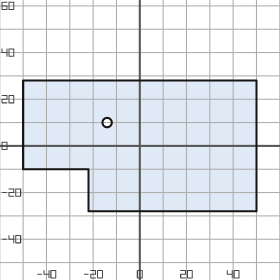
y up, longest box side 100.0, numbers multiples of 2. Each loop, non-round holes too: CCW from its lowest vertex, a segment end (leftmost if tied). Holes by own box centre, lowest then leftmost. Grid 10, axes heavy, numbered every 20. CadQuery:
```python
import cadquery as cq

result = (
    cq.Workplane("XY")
    .moveTo(-22.0, -28.0)
    .lineTo(50.0, -28.0)
    .lineTo(50.0, 28.0)
    .lineTo(-50.0, 28.0)
    .lineTo(-50.0, -10.0)
    .lineTo(-22.0, -10.0)
    .close()
    .moveTo(-14.0, 10.0)
    .circle(2.0)
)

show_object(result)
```